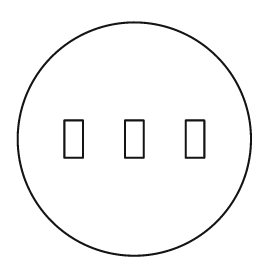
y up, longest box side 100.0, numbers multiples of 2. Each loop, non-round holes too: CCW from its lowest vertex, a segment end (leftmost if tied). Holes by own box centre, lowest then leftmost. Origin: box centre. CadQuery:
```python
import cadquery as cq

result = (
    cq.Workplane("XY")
    .moveTo(0.0, 0.0)
    .circle(50.0)
    .moveTo(-30.0, -8.0)
    .lineTo(-22.0, -8.0)
    .lineTo(-22.0, 8.0)
    .lineTo(-30.0, 8.0)
    .close()
    .moveTo(-4.0, -8.0)
    .lineTo(4.0, -8.0)
    .lineTo(4.0, 8.0)
    .lineTo(-4.0, 8.0)
    .close()
    .moveTo(22.0, -8.0)
    .lineTo(30.0, -8.0)
    .lineTo(30.0, 8.0)
    .lineTo(22.0, 8.0)
    .close()
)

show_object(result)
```